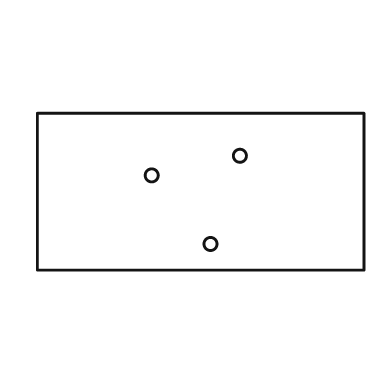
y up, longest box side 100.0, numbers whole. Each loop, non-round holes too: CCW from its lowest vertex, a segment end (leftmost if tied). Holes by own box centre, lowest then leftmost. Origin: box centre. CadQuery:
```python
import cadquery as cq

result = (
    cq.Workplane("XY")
    .moveTo(-50.0, -24.0)
    .lineTo(50.0, -24.0)
    .lineTo(50.0, 24.0)
    .lineTo(-50.0, 24.0)
    .close()
    .moveTo(3.0, -16.0)
    .circle(2.0)
    .moveTo(-15.0, 5.0)
    .circle(2.0)
    .moveTo(12.0, 11.0)
    .circle(2.0)
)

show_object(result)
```